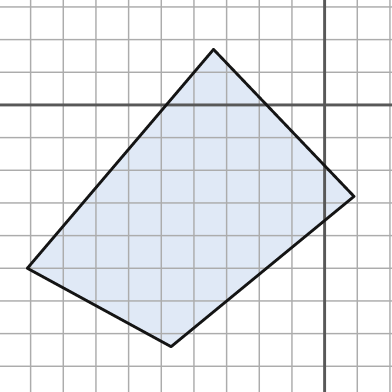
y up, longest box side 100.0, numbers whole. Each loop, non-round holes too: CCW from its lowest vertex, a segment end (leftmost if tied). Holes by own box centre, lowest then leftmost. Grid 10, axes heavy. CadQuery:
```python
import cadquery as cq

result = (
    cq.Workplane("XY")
    .moveTo(-47.0, -74.0)
    .lineTo(9.0, -28.0)
    .lineTo(-34.0, 17.0)
    .lineTo(-91.0, -50.0)
    .close()
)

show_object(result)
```